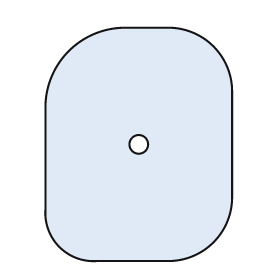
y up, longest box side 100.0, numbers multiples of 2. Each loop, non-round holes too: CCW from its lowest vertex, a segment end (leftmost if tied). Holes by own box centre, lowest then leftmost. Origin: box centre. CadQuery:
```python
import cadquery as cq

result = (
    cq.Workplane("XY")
    .moveTo(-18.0, -50.0)
    .lineTo(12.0, -50.0)
    .threePointArc((32.0, -42.0), (40.0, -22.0))
    .lineTo(40.0, 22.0)
    .threePointArc((32.0, 42.0), (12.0, 50.0))
    .lineTo(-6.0, 50.0)
    .threePointArc((-30.0, 40.0), (-40.0, 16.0))
    .lineTo(-40.0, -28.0)
    .threePointArc((-34.0, -44.0), (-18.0, -50.0))
    .close()
    .moveTo(0.0, 0.0)
    .circle(4.0)
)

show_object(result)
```